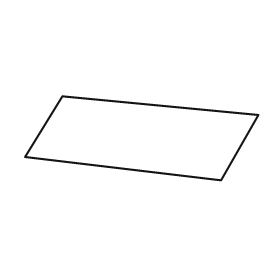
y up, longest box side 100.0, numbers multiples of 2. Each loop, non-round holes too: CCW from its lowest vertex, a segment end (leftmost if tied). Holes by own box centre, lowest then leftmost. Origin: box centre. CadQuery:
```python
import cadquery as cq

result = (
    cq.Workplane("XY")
    .moveTo(34.0, -18.0)
    .lineTo(50.0, 10.0)
    .lineTo(-34.0, 18.0)
    .lineTo(-50.0, -8.0)
    .close()
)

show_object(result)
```